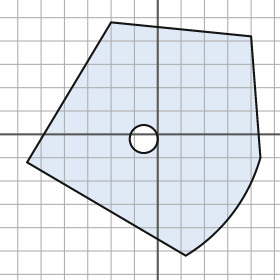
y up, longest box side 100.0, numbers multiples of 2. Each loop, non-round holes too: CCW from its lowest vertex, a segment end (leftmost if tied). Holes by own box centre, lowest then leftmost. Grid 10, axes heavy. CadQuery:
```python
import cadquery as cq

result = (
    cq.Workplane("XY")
    .moveTo(12.0, -52.0)
    .threePointArc((32.0, -34.0), (44.0, -10.0))
    .lineTo(40.0, 42.0)
    .lineTo(-20.0, 48.0)
    .lineTo(-56.0, -12.0)
    .close()
    .moveTo(-6.0, -2.0)
    .circle(6.0)
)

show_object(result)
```